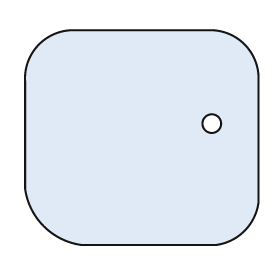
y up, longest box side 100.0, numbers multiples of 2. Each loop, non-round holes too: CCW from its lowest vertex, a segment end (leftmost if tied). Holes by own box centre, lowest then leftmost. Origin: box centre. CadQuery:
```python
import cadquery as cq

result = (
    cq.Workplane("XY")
    .moveTo(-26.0, -46.0)
    .lineTo(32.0, -46.0)
    .threePointArc((44.0, -40.0), (50.0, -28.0))
    .lineTo(50.0, 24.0)
    .threePointArc((44.0, 40.0), (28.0, 46.0))
    .lineTo(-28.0, 46.0)
    .threePointArc((-44.0, 40.0), (-50.0, 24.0))
    .lineTo(-50.0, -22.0)
    .threePointArc((-42.0, -38.0), (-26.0, -46.0))
    .close()
    .moveTo(30.0, 6.0)
    .circle(4.0)
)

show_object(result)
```